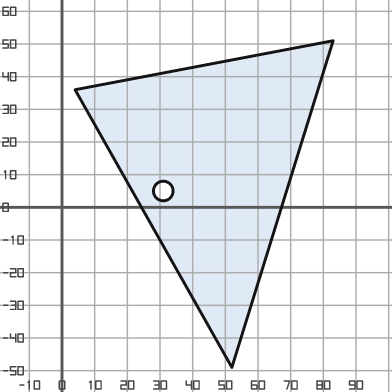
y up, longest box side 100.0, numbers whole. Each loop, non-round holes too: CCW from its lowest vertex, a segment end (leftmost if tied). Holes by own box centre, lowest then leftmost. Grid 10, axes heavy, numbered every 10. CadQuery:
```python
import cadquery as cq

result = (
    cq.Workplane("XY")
    .moveTo(52.0, -49.0)
    .lineTo(83.0, 51.0)
    .lineTo(4.0, 36.0)
    .close()
    .moveTo(31.0, 5.0)
    .circle(3.0)
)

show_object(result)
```